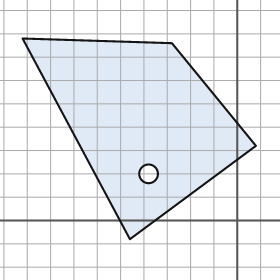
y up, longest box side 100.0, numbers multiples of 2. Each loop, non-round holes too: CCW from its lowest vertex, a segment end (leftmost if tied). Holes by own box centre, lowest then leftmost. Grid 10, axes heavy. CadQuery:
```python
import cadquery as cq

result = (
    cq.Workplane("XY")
    .moveTo(-46.0, -8.0)
    .lineTo(8.0, 32.0)
    .lineTo(-28.0, 76.0)
    .lineTo(-92.0, 78.0)
    .close()
    .moveTo(-38.0, 20.0)
    .circle(4.0)
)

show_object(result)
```